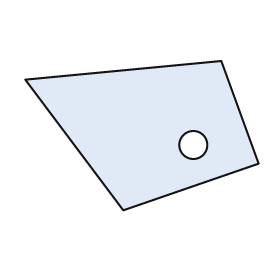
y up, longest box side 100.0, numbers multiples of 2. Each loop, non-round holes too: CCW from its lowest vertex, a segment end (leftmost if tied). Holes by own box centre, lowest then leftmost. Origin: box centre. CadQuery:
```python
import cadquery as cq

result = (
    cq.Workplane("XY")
    .moveTo(-8.0, -32.0)
    .lineTo(50.0, -12.0)
    .lineTo(34.0, 32.0)
    .lineTo(-50.0, 24.0)
    .close()
    .moveTo(22.0, -4.0)
    .circle(6.0)
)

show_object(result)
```